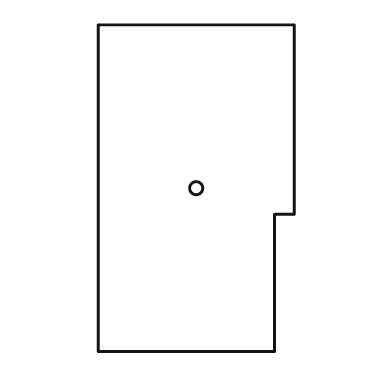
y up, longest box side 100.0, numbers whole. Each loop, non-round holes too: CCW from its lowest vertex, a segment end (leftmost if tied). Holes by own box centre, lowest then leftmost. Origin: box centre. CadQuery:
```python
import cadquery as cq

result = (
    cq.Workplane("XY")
    .moveTo(-30.0, -50.0)
    .lineTo(24.0, -50.0)
    .lineTo(24.0, -8.0)
    .lineTo(30.0, -8.0)
    .lineTo(30.0, 50.0)
    .lineTo(-30.0, 50.0)
    .close()
    .moveTo(0.0, 0.0)
    .circle(2.0)
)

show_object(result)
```